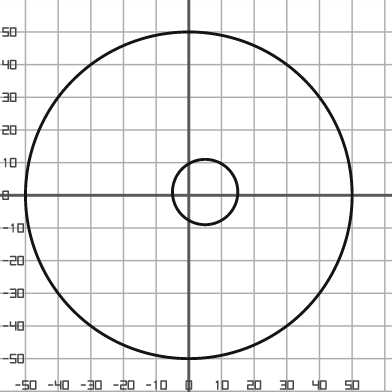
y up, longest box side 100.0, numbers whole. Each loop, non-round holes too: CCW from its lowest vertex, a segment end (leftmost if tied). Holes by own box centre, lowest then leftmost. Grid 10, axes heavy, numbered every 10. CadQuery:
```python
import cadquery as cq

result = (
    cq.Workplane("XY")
    .moveTo(0.0, 0.0)
    .circle(50.0)
    .moveTo(5.0, 1.0)
    .circle(10.0)
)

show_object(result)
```